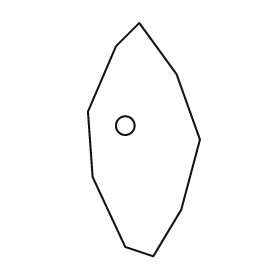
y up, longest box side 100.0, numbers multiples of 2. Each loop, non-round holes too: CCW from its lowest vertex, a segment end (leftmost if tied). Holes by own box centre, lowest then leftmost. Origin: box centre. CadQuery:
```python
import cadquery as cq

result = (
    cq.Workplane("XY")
    .moveTo(4.0, -50.0)
    .lineTo(16.0, -30.0)
    .lineTo(24.0, 0.0)
    .lineTo(14.0, 28.0)
    .lineTo(-2.0, 50.0)
    .lineTo(-12.0, 40.0)
    .lineTo(-24.0, 12.0)
    .lineTo(-22.0, -16.0)
    .lineTo(-8.0, -46.0)
    .close()
    .moveTo(-8.0, 6.0)
    .circle(4.0)
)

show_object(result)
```